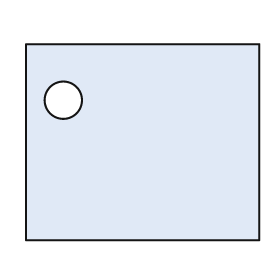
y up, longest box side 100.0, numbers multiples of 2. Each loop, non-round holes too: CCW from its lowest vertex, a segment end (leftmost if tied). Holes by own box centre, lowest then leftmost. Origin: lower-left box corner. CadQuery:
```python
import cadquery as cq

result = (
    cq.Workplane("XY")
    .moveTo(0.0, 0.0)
    .lineTo(100.0, 0.0)
    .lineTo(100.0, 84.0)
    .lineTo(0.0, 84.0)
    .close()
    .moveTo(16.0, 60.0)
    .circle(8.0)
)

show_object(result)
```